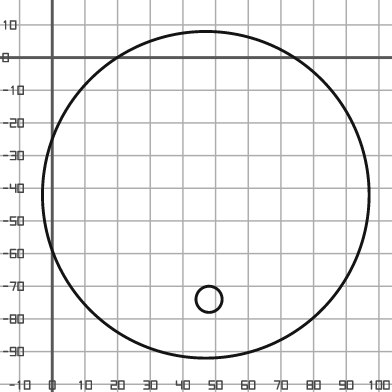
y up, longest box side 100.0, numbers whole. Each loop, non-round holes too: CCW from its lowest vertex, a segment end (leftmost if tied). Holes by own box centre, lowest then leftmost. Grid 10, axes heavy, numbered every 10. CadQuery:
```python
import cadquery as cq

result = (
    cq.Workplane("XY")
    .moveTo(47.0, -42.0)
    .circle(50.0)
    .moveTo(48.0, -74.0)
    .circle(4.0)
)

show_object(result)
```